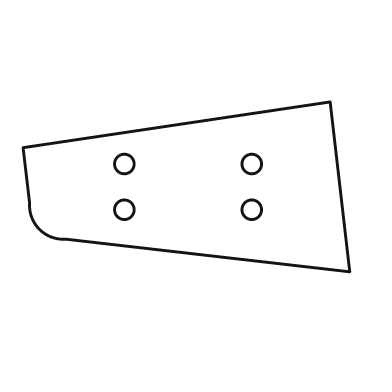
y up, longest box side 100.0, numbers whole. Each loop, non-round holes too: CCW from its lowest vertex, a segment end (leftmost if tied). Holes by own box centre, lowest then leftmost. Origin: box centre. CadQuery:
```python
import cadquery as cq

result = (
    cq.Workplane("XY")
    .moveTo(50.0, -26.0)
    .lineTo(44.0, 26.0)
    .lineTo(-50.0, 12.0)
    .lineTo(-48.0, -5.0)
    .threePointArc((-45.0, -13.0), (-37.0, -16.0))
    .close()
    .moveTo(-19.0, -7.0)
    .circle(3.0)
    .moveTo(20.0, -7.0)
    .circle(3.0)
    .moveTo(-19.0, 7.0)
    .circle(3.0)
    .moveTo(20.0, 7.0)
    .circle(3.0)
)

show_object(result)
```